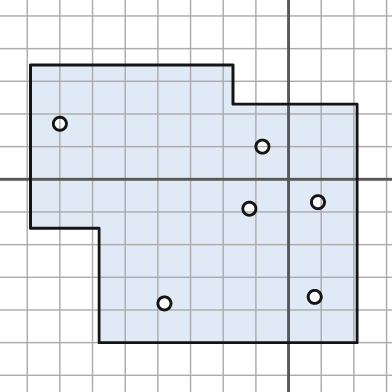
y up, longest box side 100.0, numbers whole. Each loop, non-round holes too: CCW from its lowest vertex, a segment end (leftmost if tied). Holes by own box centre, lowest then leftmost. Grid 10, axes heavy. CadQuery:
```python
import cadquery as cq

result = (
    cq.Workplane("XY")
    .moveTo(-58.0, -50.0)
    .lineTo(21.0, -50.0)
    .lineTo(21.0, 23.0)
    .lineTo(-17.0, 23.0)
    .lineTo(-17.0, 35.0)
    .lineTo(-79.0, 35.0)
    .lineTo(-79.0, -15.0)
    .lineTo(-58.0, -15.0)
    .close()
    .moveTo(-38.0, -38.0)
    .circle(2.0)
    .moveTo(8.0, -36.0)
    .circle(2.0)
    .moveTo(-12.0, -9.0)
    .circle(2.0)
    .moveTo(9.0, -7.0)
    .circle(2.0)
    .moveTo(-8.0, 10.0)
    .circle(2.0)
    .moveTo(-70.0, 17.0)
    .circle(2.0)
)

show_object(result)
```